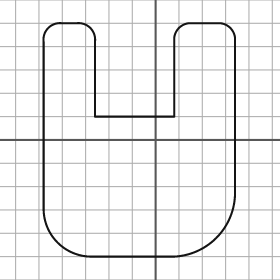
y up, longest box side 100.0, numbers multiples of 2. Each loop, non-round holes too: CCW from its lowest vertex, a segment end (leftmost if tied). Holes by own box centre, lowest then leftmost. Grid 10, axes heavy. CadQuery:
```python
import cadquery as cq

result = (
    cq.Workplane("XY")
    .moveTo(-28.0, -50.0)
    .lineTo(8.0, -50.0)
    .threePointArc((26.0, -42.0), (34.0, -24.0))
    .lineTo(34.0, 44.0)
    .threePointArc((32.0, 48.0), (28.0, 50.0))
    .lineTo(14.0, 50.0)
    .threePointArc((10.0, 48.0), (8.0, 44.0))
    .lineTo(8.0, 10.0)
    .lineTo(-26.0, 10.0)
    .lineTo(-26.0, 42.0)
    .threePointArc((-28.0, 48.0), (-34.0, 50.0))
    .lineTo(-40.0, 50.0)
    .threePointArc((-46.0, 48.0), (-48.0, 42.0))
    .lineTo(-48.0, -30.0)
    .threePointArc((-42.0, -44.0), (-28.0, -50.0))
    .close()
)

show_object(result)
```